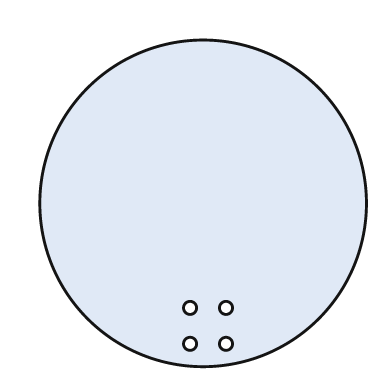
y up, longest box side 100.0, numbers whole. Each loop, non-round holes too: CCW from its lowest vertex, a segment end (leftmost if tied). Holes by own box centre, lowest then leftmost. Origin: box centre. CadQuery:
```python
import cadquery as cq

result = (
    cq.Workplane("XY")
    .moveTo(0.0, 0.0)
    .circle(50.0)
    .moveTo(-4.0, -43.0)
    .circle(2.0)
    .moveTo(7.0, -43.0)
    .circle(2.0)
    .moveTo(-4.0, -32.0)
    .circle(2.0)
    .moveTo(7.0, -32.0)
    .circle(2.0)
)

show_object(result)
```